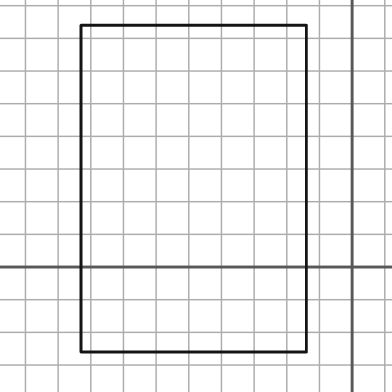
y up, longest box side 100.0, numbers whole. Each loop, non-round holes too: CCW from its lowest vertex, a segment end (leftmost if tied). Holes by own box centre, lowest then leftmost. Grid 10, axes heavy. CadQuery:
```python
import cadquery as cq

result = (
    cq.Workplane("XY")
    .moveTo(-83.0, -26.0)
    .lineTo(-14.0, -26.0)
    .lineTo(-14.0, 74.0)
    .lineTo(-83.0, 74.0)
    .close()
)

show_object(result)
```